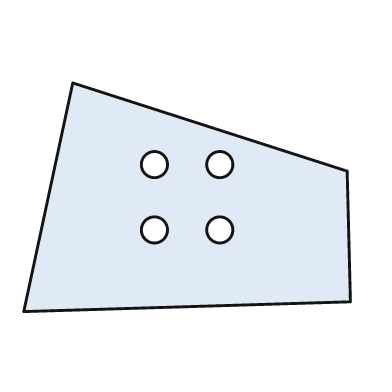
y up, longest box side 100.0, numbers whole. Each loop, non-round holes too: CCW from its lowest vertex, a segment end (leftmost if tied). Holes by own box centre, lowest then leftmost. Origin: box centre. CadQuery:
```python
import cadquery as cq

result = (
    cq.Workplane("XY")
    .moveTo(-50.0, -35.0)
    .lineTo(50.0, -32.0)
    .lineTo(49.0, 8.0)
    .lineTo(-35.0, 35.0)
    .close()
    .moveTo(-10.0, -10.0)
    .circle(4.0)
    .moveTo(10.0, -10.0)
    .circle(4.0)
    .moveTo(-10.0, 10.0)
    .circle(4.0)
    .moveTo(10.0, 10.0)
    .circle(4.0)
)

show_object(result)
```